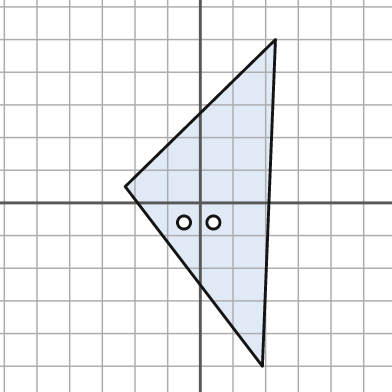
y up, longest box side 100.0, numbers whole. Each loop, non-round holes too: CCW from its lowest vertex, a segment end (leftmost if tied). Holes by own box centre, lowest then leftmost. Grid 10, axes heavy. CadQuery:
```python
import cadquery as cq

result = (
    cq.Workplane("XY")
    .moveTo(19.0, -50.0)
    .lineTo(23.0, 50.0)
    .lineTo(-23.0, 5.0)
    .close()
    .moveTo(-5.0, -6.0)
    .circle(2.0)
    .moveTo(4.0, -6.0)
    .circle(2.0)
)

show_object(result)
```